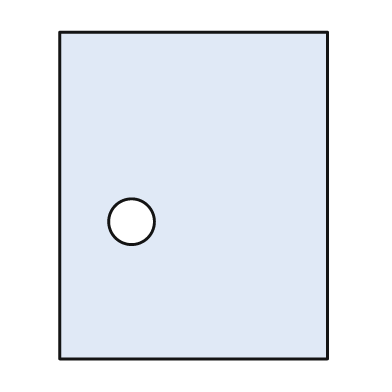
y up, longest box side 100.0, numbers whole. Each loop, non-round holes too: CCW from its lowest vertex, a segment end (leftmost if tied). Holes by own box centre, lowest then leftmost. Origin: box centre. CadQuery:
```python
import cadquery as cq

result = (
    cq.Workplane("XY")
    .moveTo(-41.0, -50.0)
    .lineTo(41.0, -50.0)
    .lineTo(41.0, 50.0)
    .lineTo(-41.0, 50.0)
    .close()
    .moveTo(-19.0, -8.0)
    .circle(7.0)
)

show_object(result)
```